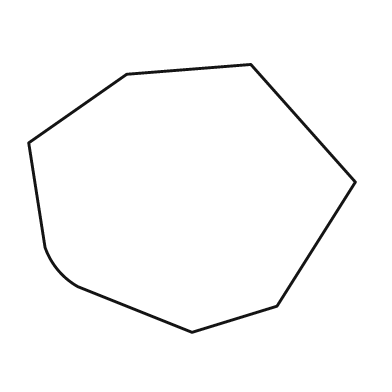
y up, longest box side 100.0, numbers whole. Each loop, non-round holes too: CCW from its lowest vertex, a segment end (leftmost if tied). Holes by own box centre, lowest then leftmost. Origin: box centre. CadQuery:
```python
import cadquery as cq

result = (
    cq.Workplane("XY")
    .moveTo(0.0, -41.0)
    .lineTo(26.0, -33.0)
    .lineTo(50.0, 5.0)
    .lineTo(18.0, 41.0)
    .lineTo(-20.0, 38.0)
    .lineTo(-50.0, 17.0)
    .lineTo(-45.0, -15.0)
    .threePointArc((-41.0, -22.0), (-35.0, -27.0))
    .close()
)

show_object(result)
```